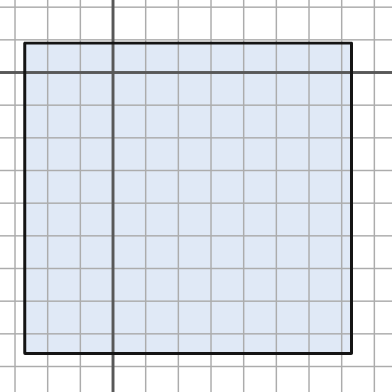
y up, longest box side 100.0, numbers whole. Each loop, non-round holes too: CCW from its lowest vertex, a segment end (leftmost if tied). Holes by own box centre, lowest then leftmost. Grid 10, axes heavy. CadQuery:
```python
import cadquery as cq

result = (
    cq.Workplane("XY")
    .moveTo(-27.0, -86.0)
    .lineTo(73.0, -86.0)
    .lineTo(73.0, 9.0)
    .lineTo(-27.0, 9.0)
    .close()
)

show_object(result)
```